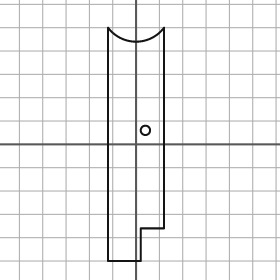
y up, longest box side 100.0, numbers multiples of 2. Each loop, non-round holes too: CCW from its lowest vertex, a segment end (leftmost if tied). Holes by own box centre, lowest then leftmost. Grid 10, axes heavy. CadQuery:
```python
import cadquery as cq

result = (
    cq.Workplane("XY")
    .moveTo(-12.0, -50.0)
    .lineTo(2.0, -50.0)
    .lineTo(2.0, -36.0)
    .lineTo(12.0, -36.0)
    .lineTo(12.0, 50.0)
    .threePointArc((0.0, 44.0), (-12.0, 50.0))
    .close()
    .moveTo(4.0, 6.0)
    .circle(2.0)
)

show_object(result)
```